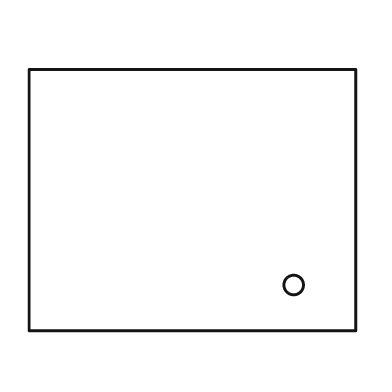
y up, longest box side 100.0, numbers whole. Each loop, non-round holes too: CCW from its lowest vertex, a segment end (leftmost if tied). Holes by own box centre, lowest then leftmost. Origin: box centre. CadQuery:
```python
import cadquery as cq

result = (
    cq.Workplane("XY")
    .moveTo(-50.0, -40.0)
    .lineTo(50.0, -40.0)
    .lineTo(50.0, 40.0)
    .lineTo(-50.0, 40.0)
    .close()
    .moveTo(31.0, -26.0)
    .circle(3.0)
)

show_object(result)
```